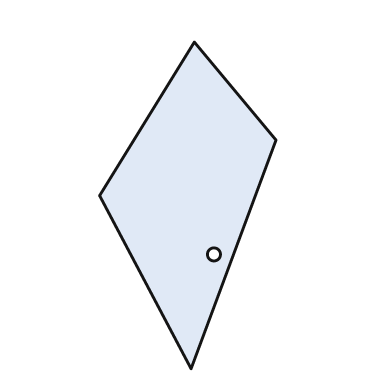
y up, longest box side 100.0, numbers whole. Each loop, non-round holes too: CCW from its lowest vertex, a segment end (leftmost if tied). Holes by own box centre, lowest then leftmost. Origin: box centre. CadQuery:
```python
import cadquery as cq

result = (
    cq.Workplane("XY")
    .moveTo(1.0, -50.0)
    .lineTo(27.0, 20.0)
    .lineTo(2.0, 50.0)
    .lineTo(-27.0, 3.0)
    .close()
    .moveTo(8.0, -15.0)
    .circle(2.0)
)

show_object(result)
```